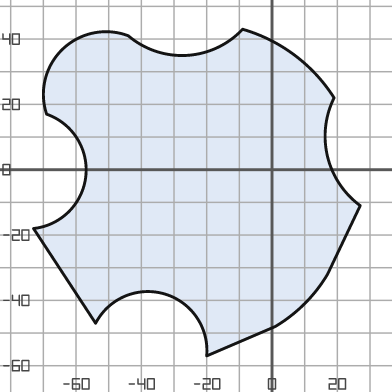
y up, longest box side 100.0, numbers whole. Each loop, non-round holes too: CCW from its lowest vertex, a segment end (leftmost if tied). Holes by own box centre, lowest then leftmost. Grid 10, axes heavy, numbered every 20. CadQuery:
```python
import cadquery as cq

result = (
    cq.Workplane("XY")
    .moveTo(-20.0, -57.0)
    .lineTo(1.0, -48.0)
    .threePointArc((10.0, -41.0), (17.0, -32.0))
    .lineTo(27.0, -11.0)
    .threePointArc((17.0, 4.0), (19.0, 22.0))
    .threePointArc((7.0, 35.0), (-9.0, 43.0))
    .threePointArc((-26.0, 35.0), (-44.0, 41.0))
    .threePointArc((-64.0, 37.0), (-69.0, 17.0))
    .threePointArc((-57.0, -2.0), (-73.0, -18.0))
    .lineTo(-54.0, -47.0)
    .threePointArc((-33.0, -38.0), (-20.0, -57.0))
    .close()
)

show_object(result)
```